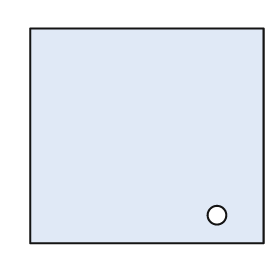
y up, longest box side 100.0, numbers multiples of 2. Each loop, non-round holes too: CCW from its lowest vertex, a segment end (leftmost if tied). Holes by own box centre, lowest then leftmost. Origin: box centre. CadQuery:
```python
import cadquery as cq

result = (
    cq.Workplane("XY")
    .moveTo(-50.0, -46.0)
    .lineTo(50.0, -46.0)
    .lineTo(50.0, 46.0)
    .lineTo(-50.0, 46.0)
    .close()
    .moveTo(30.0, -34.0)
    .circle(4.0)
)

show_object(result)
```